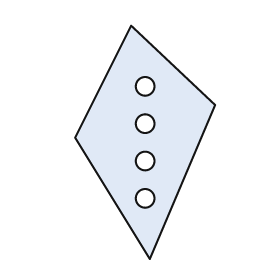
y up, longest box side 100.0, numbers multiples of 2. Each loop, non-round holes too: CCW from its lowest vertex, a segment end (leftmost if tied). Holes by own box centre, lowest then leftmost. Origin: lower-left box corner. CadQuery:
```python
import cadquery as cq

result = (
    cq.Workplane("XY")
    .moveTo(32.0, 0.0)
    .lineTo(60.0, 66.0)
    .lineTo(24.0, 100.0)
    .lineTo(0.0, 52.0)
    .close()
    .moveTo(30.0, 26.0)
    .circle(4.0)
    .moveTo(30.0, 42.0)
    .circle(4.0)
    .moveTo(30.0, 58.0)
    .circle(4.0)
    .moveTo(30.0, 74.0)
    .circle(4.0)
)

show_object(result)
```